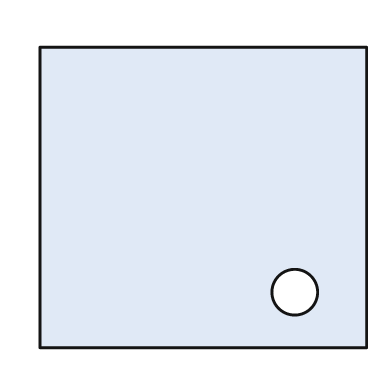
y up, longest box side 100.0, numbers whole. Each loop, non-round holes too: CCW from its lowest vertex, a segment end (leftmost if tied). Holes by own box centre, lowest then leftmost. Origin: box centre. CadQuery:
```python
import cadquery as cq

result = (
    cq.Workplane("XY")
    .moveTo(-50.0, -46.0)
    .lineTo(50.0, -46.0)
    .lineTo(50.0, 46.0)
    .lineTo(-50.0, 46.0)
    .close()
    .moveTo(28.0, -29.0)
    .circle(7.0)
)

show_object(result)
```